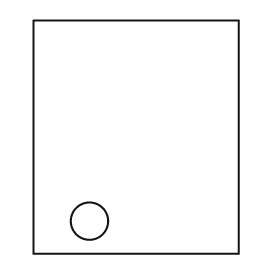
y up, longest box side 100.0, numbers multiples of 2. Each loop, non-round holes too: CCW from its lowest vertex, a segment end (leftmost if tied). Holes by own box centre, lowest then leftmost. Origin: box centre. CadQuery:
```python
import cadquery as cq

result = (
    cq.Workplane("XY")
    .moveTo(-44.0, -50.0)
    .lineTo(44.0, -50.0)
    .lineTo(44.0, 50.0)
    .lineTo(-44.0, 50.0)
    .close()
    .moveTo(-20.0, -36.0)
    .circle(8.0)
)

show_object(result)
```